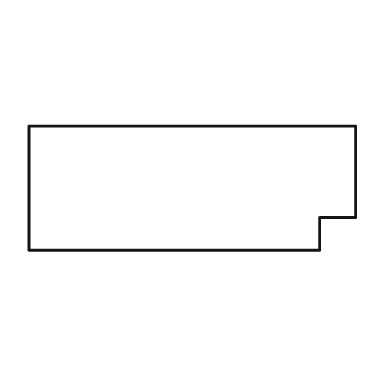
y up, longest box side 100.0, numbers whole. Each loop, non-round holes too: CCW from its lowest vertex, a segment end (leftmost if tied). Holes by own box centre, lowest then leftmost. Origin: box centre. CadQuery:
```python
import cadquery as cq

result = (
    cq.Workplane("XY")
    .moveTo(-50.0, -19.0)
    .lineTo(39.0, -19.0)
    .lineTo(39.0, -9.0)
    .lineTo(50.0, -9.0)
    .lineTo(50.0, 19.0)
    .lineTo(-50.0, 19.0)
    .close()
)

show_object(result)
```